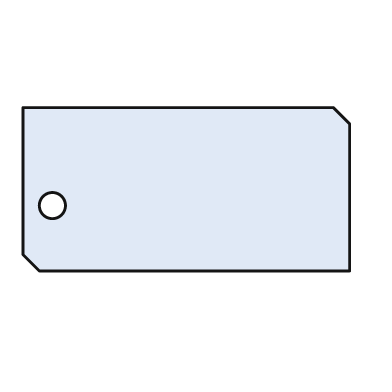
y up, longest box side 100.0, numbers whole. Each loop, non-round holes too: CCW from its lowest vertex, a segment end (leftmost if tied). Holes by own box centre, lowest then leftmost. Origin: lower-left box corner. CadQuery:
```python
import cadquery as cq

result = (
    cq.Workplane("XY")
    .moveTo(5.0, 0.0)
    .lineTo(100.0, 0.0)
    .lineTo(100.0, 45.0)
    .lineTo(95.0, 50.0)
    .lineTo(0.0, 50.0)
    .lineTo(0.0, 5.0)
    .close()
    .moveTo(9.0, 20.0)
    .circle(4.0)
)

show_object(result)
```